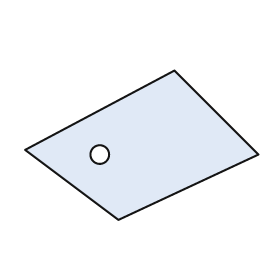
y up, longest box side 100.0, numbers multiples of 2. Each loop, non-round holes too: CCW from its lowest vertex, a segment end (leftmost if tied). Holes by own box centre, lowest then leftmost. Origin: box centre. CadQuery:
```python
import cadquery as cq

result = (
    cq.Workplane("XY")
    .moveTo(-10.0, -32.0)
    .lineTo(50.0, -4.0)
    .lineTo(14.0, 32.0)
    .lineTo(-50.0, -2.0)
    .close()
    .moveTo(-18.0, -4.0)
    .circle(4.0)
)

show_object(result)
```